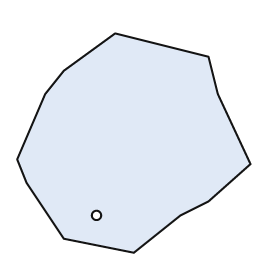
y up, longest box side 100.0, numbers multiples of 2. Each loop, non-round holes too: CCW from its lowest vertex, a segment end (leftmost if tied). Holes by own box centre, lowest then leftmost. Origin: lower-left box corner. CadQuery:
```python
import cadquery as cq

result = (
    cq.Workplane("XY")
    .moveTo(50.0, 0.0)
    .lineTo(70.0, 16.0)
    .lineTo(82.0, 22.0)
    .lineTo(100.0, 38.0)
    .lineTo(86.0, 68.0)
    .lineTo(82.0, 84.0)
    .lineTo(42.0, 94.0)
    .lineTo(20.0, 78.0)
    .lineTo(12.0, 68.0)
    .lineTo(0.0, 40.0)
    .lineTo(4.0, 30.0)
    .lineTo(20.0, 6.0)
    .close()
    .moveTo(34.0, 16.0)
    .circle(2.0)
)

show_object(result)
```